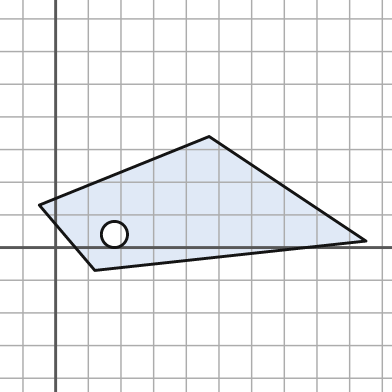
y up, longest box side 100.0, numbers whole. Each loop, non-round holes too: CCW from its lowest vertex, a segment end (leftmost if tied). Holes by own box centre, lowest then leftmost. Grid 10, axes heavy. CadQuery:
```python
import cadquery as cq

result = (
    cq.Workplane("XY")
    .moveTo(12.0, -7.0)
    .lineTo(95.0, 2.0)
    .lineTo(47.0, 34.0)
    .lineTo(-5.0, 13.0)
    .close()
    .moveTo(18.0, 4.0)
    .circle(4.0)
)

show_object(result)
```